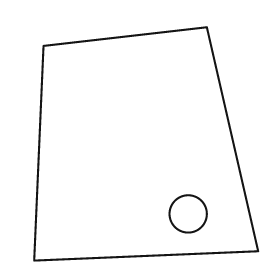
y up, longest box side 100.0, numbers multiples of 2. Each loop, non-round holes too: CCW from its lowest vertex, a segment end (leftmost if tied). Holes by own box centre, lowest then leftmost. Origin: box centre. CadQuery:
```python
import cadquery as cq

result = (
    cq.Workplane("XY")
    .moveTo(-48.0, -50.0)
    .lineTo(48.0, -46.0)
    .lineTo(26.0, 50.0)
    .lineTo(-44.0, 42.0)
    .close()
    .moveTo(18.0, -30.0)
    .circle(8.0)
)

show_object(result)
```